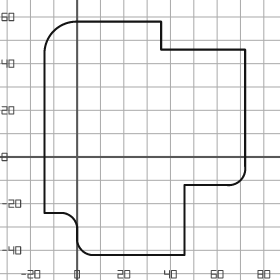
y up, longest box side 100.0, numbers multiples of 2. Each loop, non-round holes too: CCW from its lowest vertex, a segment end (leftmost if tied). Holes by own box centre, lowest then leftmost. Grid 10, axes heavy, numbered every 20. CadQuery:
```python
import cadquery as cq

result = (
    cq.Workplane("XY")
    .moveTo(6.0, -42.0)
    .lineTo(46.0, -42.0)
    .lineTo(46.0, -12.0)
    .lineTo(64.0, -12.0)
    .threePointArc((70.0, -10.0), (72.0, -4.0))
    .lineTo(72.0, 46.0)
    .lineTo(36.0, 46.0)
    .lineTo(36.0, 58.0)
    .lineTo(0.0, 58.0)
    .threePointArc((-10.0, 54.0), (-14.0, 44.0))
    .lineTo(-14.0, -24.0)
    .lineTo(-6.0, -24.0)
    .threePointArc((-2.0, -26.0), (0.0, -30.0))
    .lineTo(0.0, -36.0)
    .threePointArc((2.0, -40.0), (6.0, -42.0))
    .close()
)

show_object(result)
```